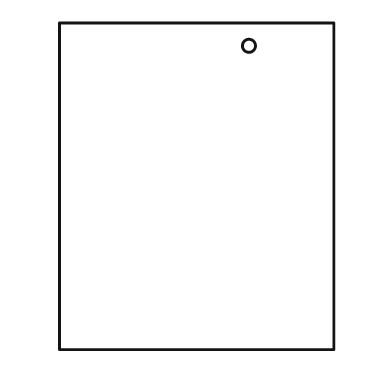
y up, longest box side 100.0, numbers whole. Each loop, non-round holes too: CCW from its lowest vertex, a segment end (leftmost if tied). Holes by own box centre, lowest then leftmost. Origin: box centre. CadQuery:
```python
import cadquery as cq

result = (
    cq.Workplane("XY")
    .moveTo(-42.0, -50.0)
    .lineTo(42.0, -50.0)
    .lineTo(42.0, 50.0)
    .lineTo(-42.0, 50.0)
    .close()
    .moveTo(16.0, 43.0)
    .circle(2.0)
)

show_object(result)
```